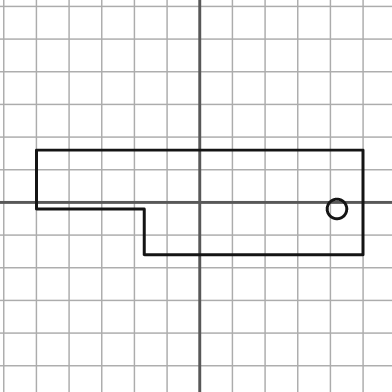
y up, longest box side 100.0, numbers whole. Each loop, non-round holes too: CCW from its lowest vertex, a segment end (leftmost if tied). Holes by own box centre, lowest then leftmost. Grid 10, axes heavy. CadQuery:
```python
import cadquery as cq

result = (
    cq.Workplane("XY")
    .moveTo(-17.0, -16.0)
    .lineTo(50.0, -16.0)
    .lineTo(50.0, 16.0)
    .lineTo(-50.0, 16.0)
    .lineTo(-50.0, -2.0)
    .lineTo(-17.0, -2.0)
    .close()
    .moveTo(42.0, -2.0)
    .circle(3.0)
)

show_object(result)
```